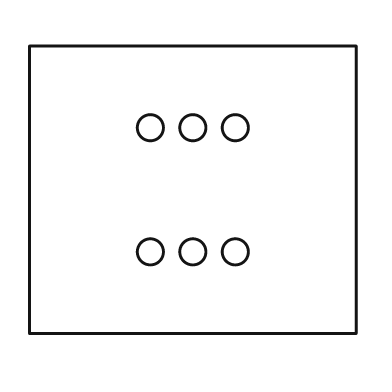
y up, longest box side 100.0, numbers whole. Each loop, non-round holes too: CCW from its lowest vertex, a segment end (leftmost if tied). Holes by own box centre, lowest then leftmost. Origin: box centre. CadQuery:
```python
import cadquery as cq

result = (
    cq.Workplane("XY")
    .moveTo(-50.0, -44.0)
    .lineTo(50.0, -44.0)
    .lineTo(50.0, 44.0)
    .lineTo(-50.0, 44.0)
    .close()
    .moveTo(-13.0, -19.0)
    .circle(4.0)
    .moveTo(0.0, -19.0)
    .circle(4.0)
    .moveTo(13.0, -19.0)
    .circle(4.0)
    .moveTo(-13.0, 19.0)
    .circle(4.0)
    .moveTo(0.0, 19.0)
    .circle(4.0)
    .moveTo(13.0, 19.0)
    .circle(4.0)
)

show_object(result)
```